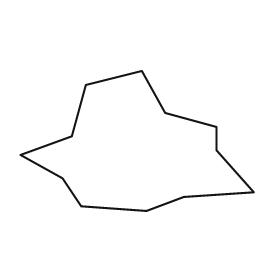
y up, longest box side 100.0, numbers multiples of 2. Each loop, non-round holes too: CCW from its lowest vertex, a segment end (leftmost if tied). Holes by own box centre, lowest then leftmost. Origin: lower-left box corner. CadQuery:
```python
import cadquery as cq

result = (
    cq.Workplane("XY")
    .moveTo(54.0, 0.0)
    .lineTo(70.0, 6.0)
    .lineTo(100.0, 8.0)
    .lineTo(84.0, 26.0)
    .lineTo(84.0, 36.0)
    .lineTo(62.0, 42.0)
    .lineTo(52.0, 60.0)
    .lineTo(28.0, 54.0)
    .lineTo(22.0, 32.0)
    .lineTo(0.0, 24.0)
    .lineTo(18.0, 14.0)
    .lineTo(26.0, 2.0)
    .close()
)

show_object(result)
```